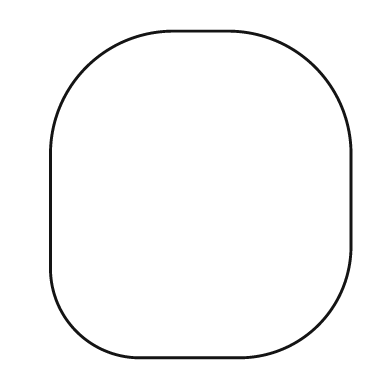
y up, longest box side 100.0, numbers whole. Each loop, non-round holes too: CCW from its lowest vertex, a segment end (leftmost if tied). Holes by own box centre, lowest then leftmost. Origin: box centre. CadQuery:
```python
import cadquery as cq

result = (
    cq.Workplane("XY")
    .moveTo(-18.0, -50.0)
    .lineTo(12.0, -50.0)
    .threePointArc((36.0, -40.0), (46.0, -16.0))
    .lineTo(46.0, 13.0)
    .threePointArc((35.0, 39.0), (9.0, 50.0))
    .lineTo(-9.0, 50.0)
    .threePointArc((-35.0, 39.0), (-46.0, 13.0))
    .lineTo(-46.0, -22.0)
    .threePointArc((-38.0, -42.0), (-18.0, -50.0))
    .close()
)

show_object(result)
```